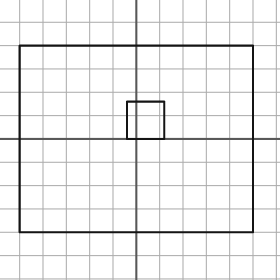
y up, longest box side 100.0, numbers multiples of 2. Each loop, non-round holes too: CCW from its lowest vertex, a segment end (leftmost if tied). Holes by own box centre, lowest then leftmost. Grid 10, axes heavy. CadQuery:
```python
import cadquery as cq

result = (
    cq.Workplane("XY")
    .moveTo(-50.0, -40.0)
    .lineTo(50.0, -40.0)
    .lineTo(50.0, 40.0)
    .lineTo(-50.0, 40.0)
    .close()
    .moveTo(-4.0, 0.0)
    .lineTo(12.0, 0.0)
    .lineTo(12.0, 16.0)
    .lineTo(-4.0, 16.0)
    .close()
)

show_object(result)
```